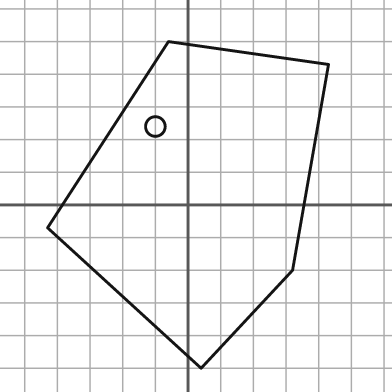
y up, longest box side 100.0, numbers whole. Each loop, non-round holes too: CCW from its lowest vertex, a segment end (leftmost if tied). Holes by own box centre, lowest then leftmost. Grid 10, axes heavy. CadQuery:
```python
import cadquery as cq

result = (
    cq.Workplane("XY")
    .moveTo(4.0, -50.0)
    .lineTo(32.0, -20.0)
    .lineTo(43.0, 43.0)
    .lineTo(-6.0, 50.0)
    .lineTo(-43.0, -7.0)
    .close()
    .moveTo(-10.0, 24.0)
    .circle(3.0)
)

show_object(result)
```